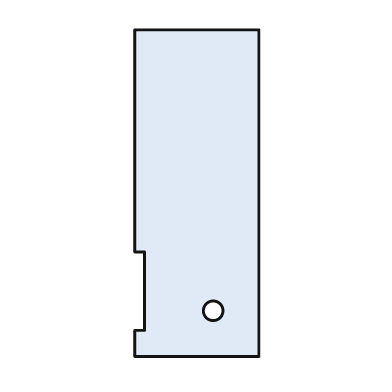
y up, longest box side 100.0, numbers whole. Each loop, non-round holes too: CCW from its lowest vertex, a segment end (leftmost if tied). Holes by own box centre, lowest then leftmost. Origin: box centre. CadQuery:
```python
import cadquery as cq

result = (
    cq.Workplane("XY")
    .moveTo(-19.0, -50.0)
    .lineTo(19.0, -50.0)
    .lineTo(19.0, 50.0)
    .lineTo(-19.0, 50.0)
    .lineTo(-19.0, -18.0)
    .lineTo(-16.0, -18.0)
    .lineTo(-16.0, -42.0)
    .lineTo(-19.0, -42.0)
    .close()
    .moveTo(5.0, -36.0)
    .circle(3.0)
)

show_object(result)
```